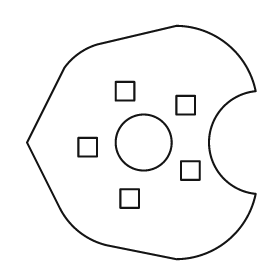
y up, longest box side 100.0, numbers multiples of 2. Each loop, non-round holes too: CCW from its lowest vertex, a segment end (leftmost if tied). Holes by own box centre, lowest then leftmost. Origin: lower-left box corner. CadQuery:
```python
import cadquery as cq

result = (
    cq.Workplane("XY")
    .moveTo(64.0, 0.0)
    .threePointArc((86.0, 8.0), (98.0, 28.0))
    .threePointArc((78.0, 50.0), (98.0, 72.0))
    .threePointArc((86.0, 92.0), (64.0, 100.0))
    .lineTo(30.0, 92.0)
    .threePointArc((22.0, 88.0), (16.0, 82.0))
    .lineTo(0.0, 50.0)
    .lineTo(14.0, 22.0)
    .threePointArc((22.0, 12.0), (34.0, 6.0))
    .close()
    .moveTo(40.0, 22.0)
    .lineTo(48.0, 22.0)
    .lineTo(48.0, 30.0)
    .lineTo(40.0, 30.0)
    .close()
    .moveTo(66.0, 34.0)
    .lineTo(74.0, 34.0)
    .lineTo(74.0, 42.0)
    .lineTo(66.0, 42.0)
    .close()
    .moveTo(22.0, 44.0)
    .lineTo(30.0, 44.0)
    .lineTo(30.0, 52.0)
    .lineTo(22.0, 52.0)
    .close()
    .moveTo(50.0, 50.0)
    .circle(12.0)
    .moveTo(64.0, 62.0)
    .lineTo(72.0, 62.0)
    .lineTo(72.0, 70.0)
    .lineTo(64.0, 70.0)
    .close()
    .moveTo(38.0, 68.0)
    .lineTo(46.0, 68.0)
    .lineTo(46.0, 76.0)
    .lineTo(38.0, 76.0)
    .close()
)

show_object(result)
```